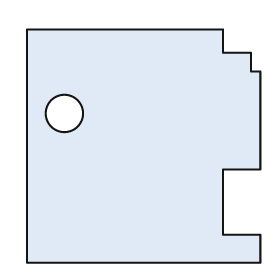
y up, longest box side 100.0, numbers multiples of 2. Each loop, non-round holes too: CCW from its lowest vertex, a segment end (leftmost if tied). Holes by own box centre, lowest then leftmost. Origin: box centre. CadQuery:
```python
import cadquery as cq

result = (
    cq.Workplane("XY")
    .moveTo(-50.0, -50.0)
    .lineTo(50.0, -50.0)
    .lineTo(50.0, -38.0)
    .lineTo(34.0, -38.0)
    .lineTo(34.0, -10.0)
    .lineTo(50.0, -10.0)
    .lineTo(50.0, 32.0)
    .lineTo(46.0, 32.0)
    .lineTo(46.0, 40.0)
    .lineTo(34.0, 40.0)
    .lineTo(34.0, 50.0)
    .lineTo(-50.0, 50.0)
    .close()
    .moveTo(-34.0, 14.0)
    .circle(8.0)
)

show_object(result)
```